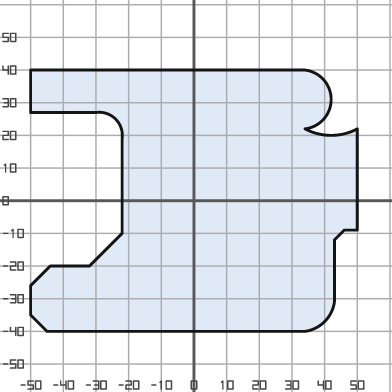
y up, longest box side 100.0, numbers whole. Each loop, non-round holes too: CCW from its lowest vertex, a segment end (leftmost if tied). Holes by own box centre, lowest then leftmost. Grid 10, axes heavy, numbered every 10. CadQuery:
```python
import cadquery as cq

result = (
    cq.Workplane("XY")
    .moveTo(-45.0, -40.0)
    .lineTo(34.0, -40.0)
    .threePointArc((40.0, -37.0), (43.0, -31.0))
    .lineTo(43.0, -12.0)
    .lineTo(46.0, -9.0)
    .lineTo(50.0, -9.0)
    .lineTo(50.0, 22.0)
    .threePointArc((42.0, 20.0), (34.0, 22.0))
    .threePointArc((42.0, 31.0), (34.0, 40.0))
    .lineTo(-50.0, 40.0)
    .lineTo(-50.0, 27.0)
    .lineTo(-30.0, 27.0)
    .threePointArc((-24.0, 25.0), (-22.0, 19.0))
    .lineTo(-22.0, -10.0)
    .lineTo(-32.0, -20.0)
    .lineTo(-44.0, -20.0)
    .lineTo(-50.0, -26.0)
    .lineTo(-50.0, -35.0)
    .close()
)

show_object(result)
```